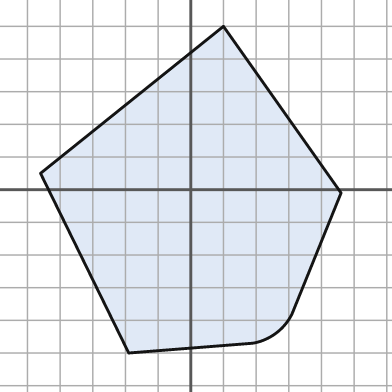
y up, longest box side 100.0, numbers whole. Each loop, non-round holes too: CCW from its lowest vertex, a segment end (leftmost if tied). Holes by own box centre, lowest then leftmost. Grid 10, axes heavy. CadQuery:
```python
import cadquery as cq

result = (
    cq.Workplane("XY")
    .moveTo(-19.0, -50.0)
    .lineTo(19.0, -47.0)
    .threePointArc((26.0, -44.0), (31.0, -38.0))
    .lineTo(46.0, -1.0)
    .lineTo(10.0, 50.0)
    .lineTo(-46.0, 5.0)
    .close()
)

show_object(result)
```